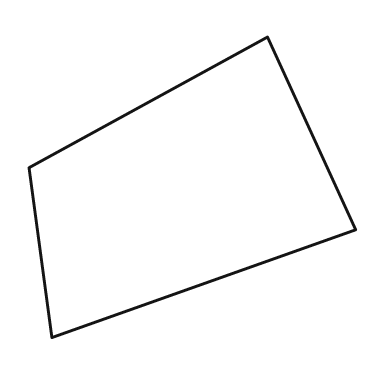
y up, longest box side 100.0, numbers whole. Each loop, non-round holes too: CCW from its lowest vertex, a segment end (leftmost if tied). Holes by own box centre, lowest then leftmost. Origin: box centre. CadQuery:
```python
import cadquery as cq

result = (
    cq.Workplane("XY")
    .moveTo(-43.0, -46.0)
    .lineTo(50.0, -13.0)
    .lineTo(23.0, 46.0)
    .lineTo(-50.0, 6.0)
    .close()
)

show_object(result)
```